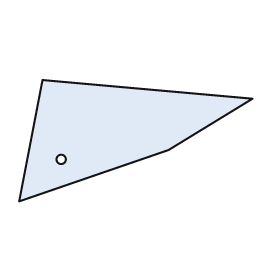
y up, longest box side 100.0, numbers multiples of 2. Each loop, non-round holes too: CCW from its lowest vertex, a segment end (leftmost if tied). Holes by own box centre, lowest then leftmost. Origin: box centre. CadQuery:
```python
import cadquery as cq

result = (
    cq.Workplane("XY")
    .moveTo(-50.0, -26.0)
    .lineTo(14.0, -4.0)
    .lineTo(50.0, 18.0)
    .lineTo(-40.0, 26.0)
    .close()
    .moveTo(-32.0, -8.0)
    .circle(2.0)
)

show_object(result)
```